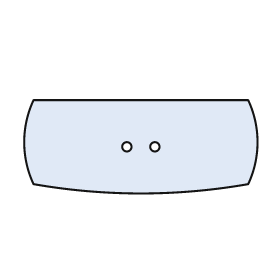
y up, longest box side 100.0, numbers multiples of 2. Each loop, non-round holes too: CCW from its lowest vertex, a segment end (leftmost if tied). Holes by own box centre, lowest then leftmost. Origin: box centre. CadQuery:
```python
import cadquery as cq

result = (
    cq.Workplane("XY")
    .moveTo(-46.0, -16.0)
    .threePointArc((0.0, -20.0), (46.0, -16.0))
    .threePointArc((50.0, 2.0), (46.0, 20.0))
    .lineTo(-46.0, 20.0)
    .threePointArc((-50.0, 2.0), (-46.0, -16.0))
    .close()
    .moveTo(-6.0, 0.0)
    .circle(2.0)
    .moveTo(6.0, 0.0)
    .circle(2.0)
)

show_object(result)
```